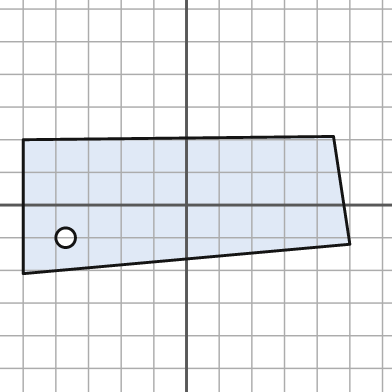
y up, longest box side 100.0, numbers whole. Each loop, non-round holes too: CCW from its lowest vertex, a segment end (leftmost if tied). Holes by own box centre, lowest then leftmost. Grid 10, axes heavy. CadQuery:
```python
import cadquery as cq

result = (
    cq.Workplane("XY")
    .moveTo(-50.0, -21.0)
    .lineTo(50.0, -12.0)
    .lineTo(45.0, 21.0)
    .lineTo(-50.0, 20.0)
    .close()
    .moveTo(-37.0, -10.0)
    .circle(3.0)
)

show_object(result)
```